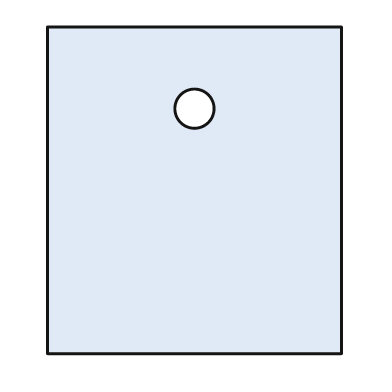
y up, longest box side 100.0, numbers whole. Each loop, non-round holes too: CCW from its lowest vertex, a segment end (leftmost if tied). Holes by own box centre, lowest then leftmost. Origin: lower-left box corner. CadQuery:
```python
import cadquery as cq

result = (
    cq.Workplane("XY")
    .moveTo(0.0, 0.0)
    .lineTo(90.0, 0.0)
    .lineTo(90.0, 100.0)
    .lineTo(0.0, 100.0)
    .close()
    .moveTo(45.0, 75.0)
    .circle(6.0)
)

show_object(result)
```